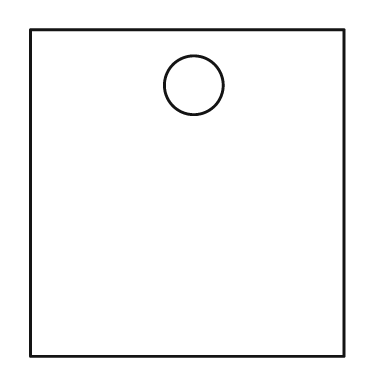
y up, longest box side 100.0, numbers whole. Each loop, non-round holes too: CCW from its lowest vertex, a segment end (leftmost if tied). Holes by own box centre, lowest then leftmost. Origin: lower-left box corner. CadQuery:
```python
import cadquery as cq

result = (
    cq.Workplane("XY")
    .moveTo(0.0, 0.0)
    .lineTo(96.0, 0.0)
    .lineTo(96.0, 100.0)
    .lineTo(0.0, 100.0)
    .close()
    .moveTo(50.0, 83.0)
    .circle(9.0)
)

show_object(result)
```